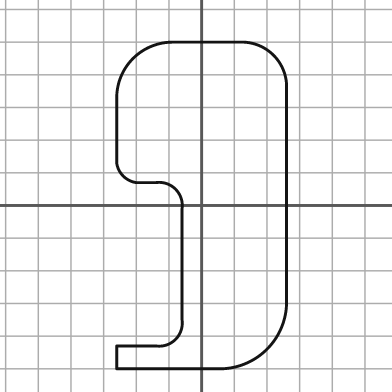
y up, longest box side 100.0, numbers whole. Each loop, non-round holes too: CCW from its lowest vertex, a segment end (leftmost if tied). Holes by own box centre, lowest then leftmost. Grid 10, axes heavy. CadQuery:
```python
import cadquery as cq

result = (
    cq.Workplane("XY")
    .moveTo(-26.0, -50.0)
    .lineTo(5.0, -50.0)
    .threePointArc((20.0, -44.0), (26.0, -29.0))
    .lineTo(26.0, 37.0)
    .threePointArc((22.0, 46.0), (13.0, 50.0))
    .lineTo(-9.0, 50.0)
    .threePointArc((-21.0, 45.0), (-26.0, 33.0))
    .lineTo(-26.0, 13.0)
    .threePointArc((-24.0, 9.0), (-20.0, 7.0))
    .lineTo(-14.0, 7.0)
    .threePointArc((-8.0, 5.0), (-6.0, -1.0))
    .lineTo(-6.0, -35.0)
    .threePointArc((-8.0, -41.0), (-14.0, -43.0))
    .lineTo(-26.0, -43.0)
    .close()
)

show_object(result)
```